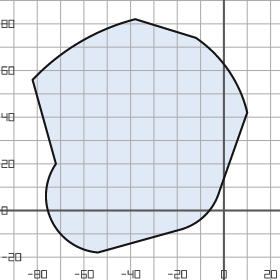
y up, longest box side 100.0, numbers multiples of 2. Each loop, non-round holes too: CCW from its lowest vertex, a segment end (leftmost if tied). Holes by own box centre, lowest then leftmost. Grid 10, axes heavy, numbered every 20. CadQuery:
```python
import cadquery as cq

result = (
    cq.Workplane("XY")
    .moveTo(-54.0, -18.0)
    .lineTo(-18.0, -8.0)
    .threePointArc((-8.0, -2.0), (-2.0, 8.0))
    .lineTo(10.0, 42.0)
    .threePointArc((2.0, 60.0), (-12.0, 74.0))
    .lineTo(-38.0, 82.0)
    .threePointArc((-62.0, 72.0), (-82.0, 56.0))
    .lineTo(-72.0, 20.0)
    .threePointArc((-74.0, -4.0), (-54.0, -18.0))
    .close()
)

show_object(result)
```